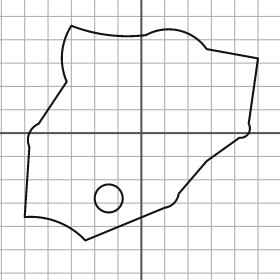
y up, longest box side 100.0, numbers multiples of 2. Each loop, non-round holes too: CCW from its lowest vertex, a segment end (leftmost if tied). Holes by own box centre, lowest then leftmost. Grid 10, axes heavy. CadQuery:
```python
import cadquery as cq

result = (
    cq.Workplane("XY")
    .moveTo(-24.0, -46.0)
    .lineTo(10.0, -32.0)
    .threePointArc((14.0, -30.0), (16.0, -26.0))
    .lineTo(28.0, -12.0)
    .lineTo(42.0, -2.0)
    .threePointArc((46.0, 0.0), (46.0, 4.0))
    .lineTo(50.0, 32.0)
    .lineTo(28.0, 36.0)
    .threePointArc((16.0, 44.0), (2.0, 42.0))
    .threePointArc((-14.0, 42.0), (-30.0, 46.0))
    .threePointArc((-34.0, 34.0), (-32.0, 22.0))
    .lineTo(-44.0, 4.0)
    .threePointArc((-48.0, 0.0), (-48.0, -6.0))
    .lineTo(-50.0, -36.0)
    .threePointArc((-36.0, -38.0), (-24.0, -46.0))
    .close()
    .moveTo(-14.0, -28.0)
    .circle(6.0)
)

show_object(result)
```